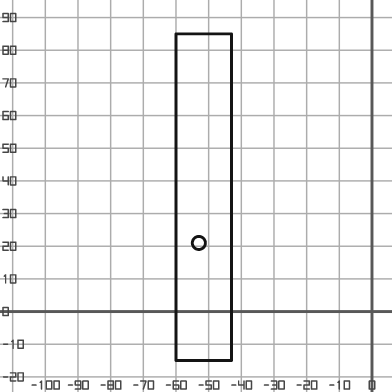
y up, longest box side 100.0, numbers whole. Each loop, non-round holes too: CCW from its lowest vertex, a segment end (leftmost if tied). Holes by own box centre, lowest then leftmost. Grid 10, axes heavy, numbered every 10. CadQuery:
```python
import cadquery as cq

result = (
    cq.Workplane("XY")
    .moveTo(-60.0, -15.0)
    .lineTo(-43.0, -15.0)
    .lineTo(-43.0, 85.0)
    .lineTo(-60.0, 85.0)
    .close()
    .moveTo(-53.0, 21.0)
    .circle(2.0)
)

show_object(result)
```